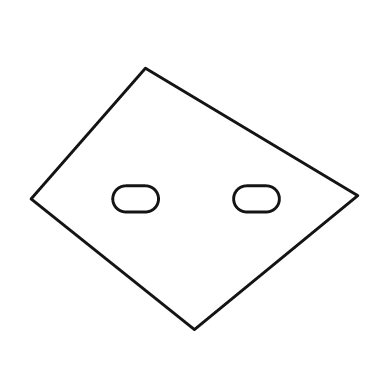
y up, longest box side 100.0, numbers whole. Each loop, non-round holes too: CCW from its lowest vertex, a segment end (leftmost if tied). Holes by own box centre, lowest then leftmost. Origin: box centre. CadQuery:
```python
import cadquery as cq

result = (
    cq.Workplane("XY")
    .moveTo(0.0, -40.0)
    .lineTo(50.0, 1.0)
    .lineTo(-15.0, 40.0)
    .lineTo(-50.0, 0.0)
    .close()
    .moveTo(-21.0, -4.0)
    .lineTo(-15.0, -4.0)
    .threePointArc((-11.0, 0.0), (-15.0, 4.0))
    .lineTo(-21.0, 4.0)
    .threePointArc((-25.0, 0.0), (-21.0, -4.0))
    .close()
    .moveTo(16.0, -4.0)
    .lineTo(22.0, -4.0)
    .threePointArc((26.0, 0.0), (22.0, 4.0))
    .lineTo(16.0, 4.0)
    .threePointArc((12.0, 0.0), (16.0, -4.0))
    .close()
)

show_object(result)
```